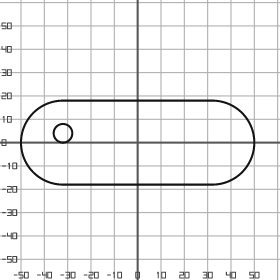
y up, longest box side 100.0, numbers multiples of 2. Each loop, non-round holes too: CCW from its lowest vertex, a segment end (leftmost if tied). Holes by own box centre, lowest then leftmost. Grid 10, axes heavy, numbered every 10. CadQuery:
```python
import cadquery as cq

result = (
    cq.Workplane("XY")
    .moveTo(-32.0, -18.0)
    .lineTo(32.0, -18.0)
    .threePointArc((50.0, 0.0), (32.0, 18.0))
    .lineTo(-32.0, 18.0)
    .threePointArc((-50.0, 0.0), (-32.0, -18.0))
    .close()
    .moveTo(-32.0, 4.0)
    .circle(4.0)
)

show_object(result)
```